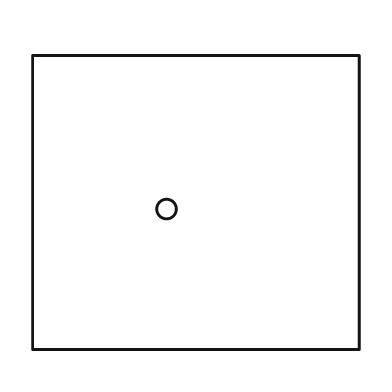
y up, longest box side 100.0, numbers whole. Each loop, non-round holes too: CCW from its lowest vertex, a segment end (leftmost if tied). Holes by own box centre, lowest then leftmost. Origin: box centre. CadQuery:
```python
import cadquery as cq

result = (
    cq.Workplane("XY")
    .moveTo(-50.0, -45.0)
    .lineTo(50.0, -45.0)
    .lineTo(50.0, 45.0)
    .lineTo(-50.0, 45.0)
    .close()
    .moveTo(-9.0, -2.0)
    .circle(3.0)
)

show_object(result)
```